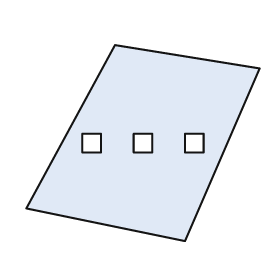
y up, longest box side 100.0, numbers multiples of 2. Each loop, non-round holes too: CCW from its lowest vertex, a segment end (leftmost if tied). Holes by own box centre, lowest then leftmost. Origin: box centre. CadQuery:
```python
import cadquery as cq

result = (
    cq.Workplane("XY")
    .moveTo(18.0, -42.0)
    .lineTo(50.0, 32.0)
    .lineTo(-12.0, 42.0)
    .lineTo(-50.0, -28.0)
    .close()
    .moveTo(-26.0, -4.0)
    .lineTo(-18.0, -4.0)
    .lineTo(-18.0, 4.0)
    .lineTo(-26.0, 4.0)
    .close()
    .moveTo(-4.0, -4.0)
    .lineTo(4.0, -4.0)
    .lineTo(4.0, 4.0)
    .lineTo(-4.0, 4.0)
    .close()
    .moveTo(18.0, -4.0)
    .lineTo(26.0, -4.0)
    .lineTo(26.0, 4.0)
    .lineTo(18.0, 4.0)
    .close()
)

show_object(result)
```